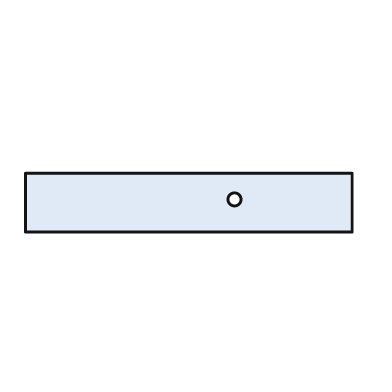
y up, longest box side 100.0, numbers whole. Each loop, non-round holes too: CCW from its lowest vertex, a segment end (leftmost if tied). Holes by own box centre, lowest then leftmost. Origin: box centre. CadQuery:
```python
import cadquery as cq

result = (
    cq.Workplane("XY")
    .moveTo(-50.0, -9.0)
    .lineTo(50.0, -9.0)
    .lineTo(50.0, 9.0)
    .lineTo(-50.0, 9.0)
    .close()
    .moveTo(14.0, 1.0)
    .circle(2.0)
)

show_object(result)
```